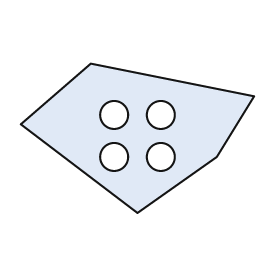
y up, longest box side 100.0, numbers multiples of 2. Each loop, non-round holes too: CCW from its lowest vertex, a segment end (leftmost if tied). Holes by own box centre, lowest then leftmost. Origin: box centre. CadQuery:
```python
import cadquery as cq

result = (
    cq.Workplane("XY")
    .moveTo(0.0, -32.0)
    .lineTo(34.0, -8.0)
    .lineTo(50.0, 18.0)
    .lineTo(-20.0, 32.0)
    .lineTo(-50.0, 6.0)
    .close()
    .moveTo(-10.0, -8.0)
    .circle(6.0)
    .moveTo(10.0, -8.0)
    .circle(6.0)
    .moveTo(-10.0, 10.0)
    .circle(6.0)
    .moveTo(10.0, 10.0)
    .circle(6.0)
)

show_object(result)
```